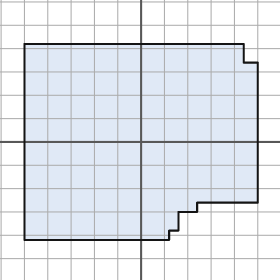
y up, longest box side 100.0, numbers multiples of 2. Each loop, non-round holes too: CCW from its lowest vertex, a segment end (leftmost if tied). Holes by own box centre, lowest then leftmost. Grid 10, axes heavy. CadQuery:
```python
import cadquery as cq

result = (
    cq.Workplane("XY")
    .moveTo(-50.0, -42.0)
    .lineTo(12.0, -42.0)
    .lineTo(12.0, -38.0)
    .lineTo(16.0, -38.0)
    .lineTo(16.0, -30.0)
    .lineTo(24.0, -30.0)
    .lineTo(24.0, -26.0)
    .lineTo(50.0, -26.0)
    .lineTo(50.0, 34.0)
    .lineTo(44.0, 34.0)
    .lineTo(44.0, 42.0)
    .lineTo(-50.0, 42.0)
    .close()
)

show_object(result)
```